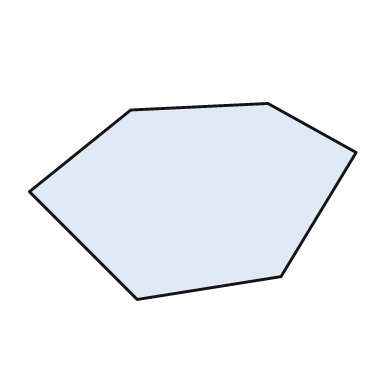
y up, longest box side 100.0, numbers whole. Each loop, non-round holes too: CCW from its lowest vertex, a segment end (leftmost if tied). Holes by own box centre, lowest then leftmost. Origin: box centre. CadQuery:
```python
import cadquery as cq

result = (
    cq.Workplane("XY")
    .moveTo(-17.0, -30.0)
    .lineTo(27.0, -23.0)
    .lineTo(50.0, 15.0)
    .lineTo(23.0, 30.0)
    .lineTo(-19.0, 28.0)
    .lineTo(-50.0, 3.0)
    .close()
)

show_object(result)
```